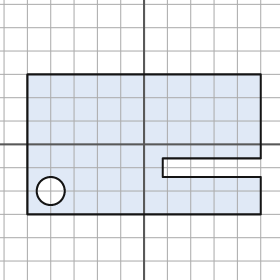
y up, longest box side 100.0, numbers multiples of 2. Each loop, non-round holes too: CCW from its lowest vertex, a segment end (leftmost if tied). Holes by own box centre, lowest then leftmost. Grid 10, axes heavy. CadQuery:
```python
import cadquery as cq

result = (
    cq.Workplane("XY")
    .moveTo(-50.0, -30.0)
    .lineTo(50.0, -30.0)
    .lineTo(50.0, -14.0)
    .lineTo(8.0, -14.0)
    .lineTo(8.0, -6.0)
    .lineTo(50.0, -6.0)
    .lineTo(50.0, 30.0)
    .lineTo(-50.0, 30.0)
    .close()
    .moveTo(-40.0, -20.0)
    .circle(6.0)
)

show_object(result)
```